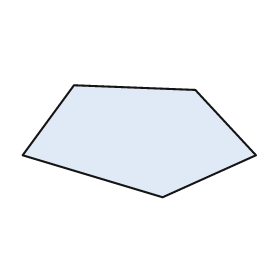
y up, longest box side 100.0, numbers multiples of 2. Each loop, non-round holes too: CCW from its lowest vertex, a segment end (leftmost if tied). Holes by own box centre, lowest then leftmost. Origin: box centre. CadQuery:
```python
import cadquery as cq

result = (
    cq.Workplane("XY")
    .moveTo(10.0, -24.0)
    .lineTo(50.0, -6.0)
    .lineTo(24.0, 22.0)
    .lineTo(-28.0, 24.0)
    .lineTo(-50.0, -6.0)
    .close()
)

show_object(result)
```